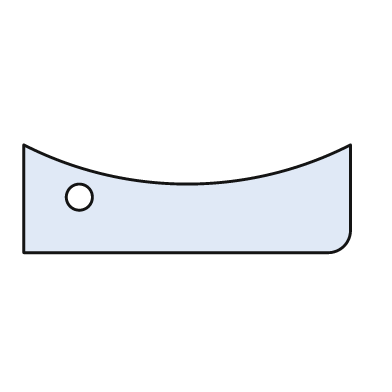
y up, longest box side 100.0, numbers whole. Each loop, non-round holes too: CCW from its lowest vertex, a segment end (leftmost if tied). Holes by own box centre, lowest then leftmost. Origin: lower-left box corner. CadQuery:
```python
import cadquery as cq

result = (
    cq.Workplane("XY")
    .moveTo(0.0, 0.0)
    .lineTo(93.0, 0.0)
    .threePointArc((98.0, 2.0), (100.0, 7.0))
    .lineTo(100.0, 33.0)
    .threePointArc((50.0, 21.0), (0.0, 33.0))
    .close()
    .moveTo(17.0, 17.0)
    .circle(4.0)
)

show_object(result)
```